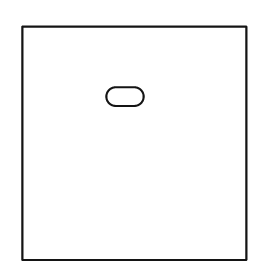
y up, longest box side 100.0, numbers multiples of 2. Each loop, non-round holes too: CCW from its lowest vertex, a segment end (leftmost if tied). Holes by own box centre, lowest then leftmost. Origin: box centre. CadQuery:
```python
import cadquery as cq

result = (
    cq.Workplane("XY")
    .moveTo(-48.0, -50.0)
    .lineTo(48.0, -50.0)
    .lineTo(48.0, 50.0)
    .lineTo(-48.0, 50.0)
    .close()
    .moveTo(-8.0, 16.0)
    .lineTo(0.0, 16.0)
    .threePointArc((4.0, 20.0), (0.0, 24.0))
    .lineTo(-8.0, 24.0)
    .threePointArc((-12.0, 20.0), (-8.0, 16.0))
    .close()
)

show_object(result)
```